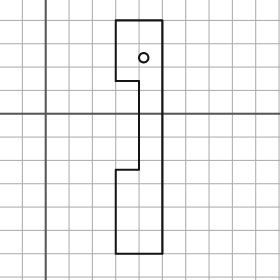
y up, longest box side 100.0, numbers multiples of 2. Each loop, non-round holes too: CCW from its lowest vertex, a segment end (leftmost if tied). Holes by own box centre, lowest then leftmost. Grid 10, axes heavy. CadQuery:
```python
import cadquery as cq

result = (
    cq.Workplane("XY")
    .moveTo(30.0, -60.0)
    .lineTo(50.0, -60.0)
    .lineTo(50.0, 40.0)
    .lineTo(30.0, 40.0)
    .lineTo(30.0, 14.0)
    .lineTo(40.0, 14.0)
    .lineTo(40.0, -24.0)
    .lineTo(30.0, -24.0)
    .close()
    .moveTo(42.0, 24.0)
    .circle(2.0)
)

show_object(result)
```